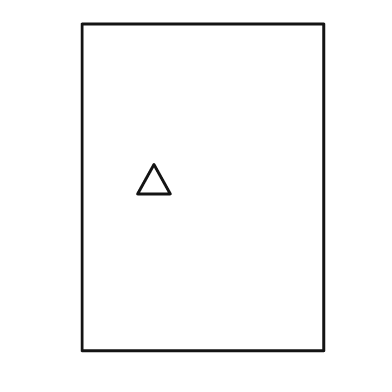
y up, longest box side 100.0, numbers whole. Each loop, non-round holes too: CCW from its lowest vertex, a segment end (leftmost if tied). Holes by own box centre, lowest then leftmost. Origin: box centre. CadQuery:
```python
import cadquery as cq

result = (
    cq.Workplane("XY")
    .moveTo(-37.0, -50.0)
    .lineTo(37.0, -50.0)
    .lineTo(37.0, 50.0)
    .lineTo(-37.0, 50.0)
    .close()
    .moveTo(-20.0, -2.0)
    .lineTo(-10.0, -2.0)
    .lineTo(-15.0, 7.0)
    .close()
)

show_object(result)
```